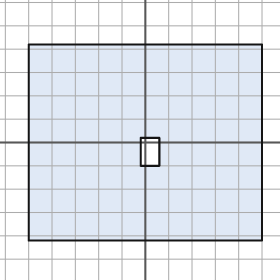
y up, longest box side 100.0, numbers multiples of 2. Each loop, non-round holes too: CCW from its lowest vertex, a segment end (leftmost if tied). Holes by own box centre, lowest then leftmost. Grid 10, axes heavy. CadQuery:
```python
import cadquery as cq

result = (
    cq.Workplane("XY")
    .moveTo(-50.0, -42.0)
    .lineTo(50.0, -42.0)
    .lineTo(50.0, 42.0)
    .lineTo(-50.0, 42.0)
    .close()
    .moveTo(-2.0, -10.0)
    .lineTo(6.0, -10.0)
    .lineTo(6.0, 2.0)
    .lineTo(-2.0, 2.0)
    .close()
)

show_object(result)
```